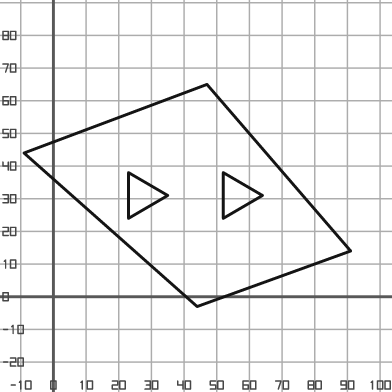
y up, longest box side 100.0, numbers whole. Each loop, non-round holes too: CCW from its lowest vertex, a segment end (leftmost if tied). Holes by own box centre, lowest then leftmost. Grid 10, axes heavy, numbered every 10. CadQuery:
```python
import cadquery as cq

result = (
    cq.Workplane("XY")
    .moveTo(44.0, -3.0)
    .lineTo(91.0, 14.0)
    .lineTo(47.0, 65.0)
    .lineTo(-9.0, 44.0)
    .close()
    .moveTo(23.0, 24.0)
    .lineTo(35.0, 31.0)
    .lineTo(23.0, 38.0)
    .close()
    .moveTo(52.0, 24.0)
    .lineTo(64.0, 31.0)
    .lineTo(52.0, 38.0)
    .close()
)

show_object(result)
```